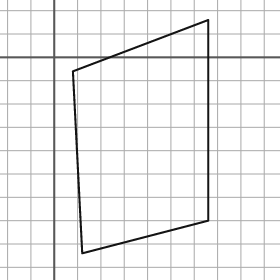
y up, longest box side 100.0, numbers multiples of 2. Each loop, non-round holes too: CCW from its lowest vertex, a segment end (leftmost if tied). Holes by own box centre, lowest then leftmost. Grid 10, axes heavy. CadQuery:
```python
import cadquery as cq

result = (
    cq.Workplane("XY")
    .moveTo(12.0, -84.0)
    .lineTo(66.0, -70.0)
    .lineTo(66.0, 16.0)
    .lineTo(8.0, -6.0)
    .close()
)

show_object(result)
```